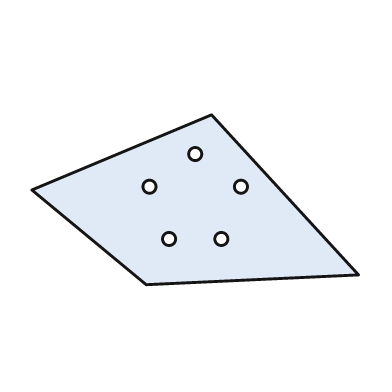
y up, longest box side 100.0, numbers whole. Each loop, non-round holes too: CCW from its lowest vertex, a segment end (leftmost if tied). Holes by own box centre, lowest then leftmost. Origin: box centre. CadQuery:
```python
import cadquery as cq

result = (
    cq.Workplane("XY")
    .moveTo(-15.0, -26.0)
    .lineTo(50.0, -23.0)
    .lineTo(5.0, 26.0)
    .lineTo(-50.0, 3.0)
    .close()
    .moveTo(-8.0, -12.0)
    .circle(2.0)
    .moveTo(8.0, -12.0)
    .circle(2.0)
    .moveTo(-14.0, 4.0)
    .circle(2.0)
    .moveTo(14.0, 4.0)
    .circle(2.0)
    .moveTo(0.0, 14.0)
    .circle(2.0)
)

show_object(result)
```